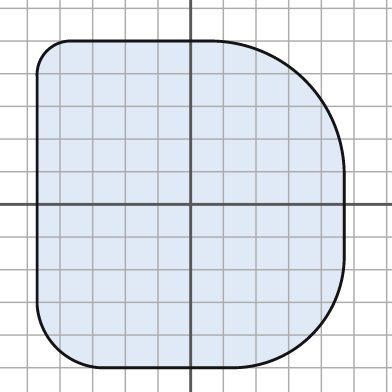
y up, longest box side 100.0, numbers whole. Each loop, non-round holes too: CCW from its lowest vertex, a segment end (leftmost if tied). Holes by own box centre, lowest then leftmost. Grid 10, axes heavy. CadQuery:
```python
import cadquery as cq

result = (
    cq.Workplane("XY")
    .moveTo(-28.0, -50.0)
    .lineTo(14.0, -50.0)
    .threePointArc((37.0, -40.0), (47.0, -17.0))
    .lineTo(47.0, 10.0)
    .threePointArc((35.0, 38.0), (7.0, 50.0))
    .lineTo(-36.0, 50.0)
    .threePointArc((-44.0, 47.0), (-47.0, 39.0))
    .lineTo(-47.0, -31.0)
    .threePointArc((-41.0, -44.0), (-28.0, -50.0))
    .close()
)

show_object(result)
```